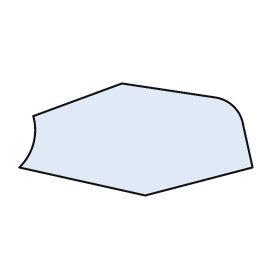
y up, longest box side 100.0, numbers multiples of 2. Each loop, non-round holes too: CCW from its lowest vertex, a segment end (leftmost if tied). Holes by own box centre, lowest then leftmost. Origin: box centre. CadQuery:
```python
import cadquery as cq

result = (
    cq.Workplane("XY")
    .moveTo(4.0, -24.0)
    .lineTo(50.0, -12.0)
    .lineTo(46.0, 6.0)
    .threePointArc((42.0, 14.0), (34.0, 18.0))
    .lineTo(-6.0, 24.0)
    .lineTo(-44.0, 10.0)
    .threePointArc((-44.0, -2.0), (-50.0, -12.0))
    .close()
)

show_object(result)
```